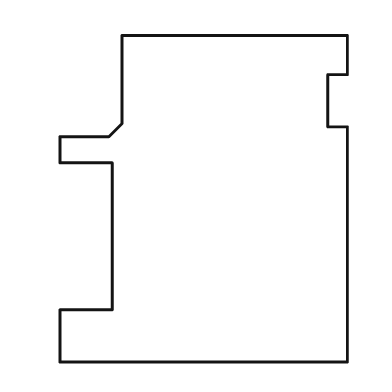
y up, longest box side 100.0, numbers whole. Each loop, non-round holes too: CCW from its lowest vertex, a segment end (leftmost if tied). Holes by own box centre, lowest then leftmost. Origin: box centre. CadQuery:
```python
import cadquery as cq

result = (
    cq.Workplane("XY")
    .moveTo(-44.0, -50.0)
    .lineTo(44.0, -50.0)
    .lineTo(44.0, 22.0)
    .lineTo(38.0, 22.0)
    .lineTo(38.0, 38.0)
    .lineTo(44.0, 38.0)
    .lineTo(44.0, 50.0)
    .lineTo(-25.0, 50.0)
    .lineTo(-25.0, 23.0)
    .lineTo(-29.0, 19.0)
    .lineTo(-44.0, 19.0)
    .lineTo(-44.0, 11.0)
    .lineTo(-28.0, 11.0)
    .lineTo(-28.0, -34.0)
    .lineTo(-44.0, -34.0)
    .close()
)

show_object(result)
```